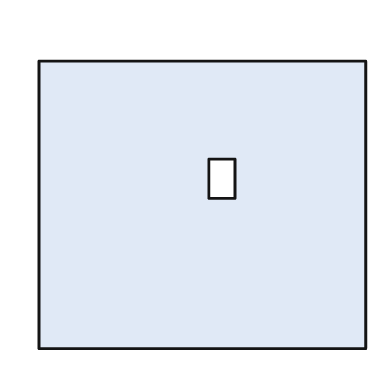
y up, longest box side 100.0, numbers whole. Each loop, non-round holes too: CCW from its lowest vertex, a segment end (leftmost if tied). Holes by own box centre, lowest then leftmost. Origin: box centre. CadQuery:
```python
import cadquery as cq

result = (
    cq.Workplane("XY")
    .moveTo(-50.0, -44.0)
    .lineTo(50.0, -44.0)
    .lineTo(50.0, 44.0)
    .lineTo(-50.0, 44.0)
    .close()
    .moveTo(2.0, 2.0)
    .lineTo(10.0, 2.0)
    .lineTo(10.0, 14.0)
    .lineTo(2.0, 14.0)
    .close()
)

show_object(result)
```